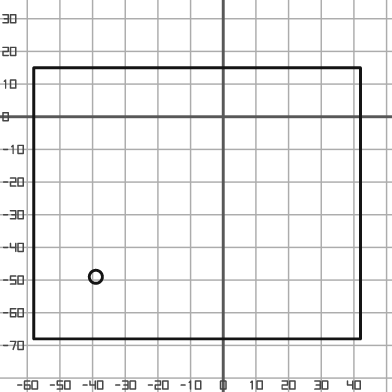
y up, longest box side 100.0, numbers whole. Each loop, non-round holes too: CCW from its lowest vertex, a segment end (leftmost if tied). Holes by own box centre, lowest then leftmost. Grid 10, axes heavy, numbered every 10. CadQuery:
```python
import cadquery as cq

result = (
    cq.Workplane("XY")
    .moveTo(-58.0, -68.0)
    .lineTo(42.0, -68.0)
    .lineTo(42.0, 15.0)
    .lineTo(-58.0, 15.0)
    .close()
    .moveTo(-39.0, -49.0)
    .circle(2.0)
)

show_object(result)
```